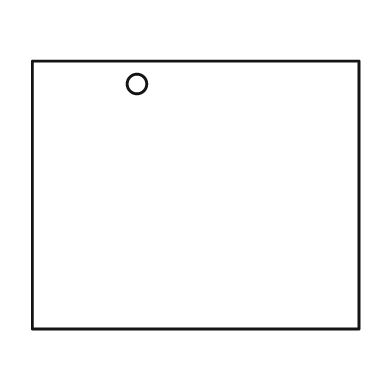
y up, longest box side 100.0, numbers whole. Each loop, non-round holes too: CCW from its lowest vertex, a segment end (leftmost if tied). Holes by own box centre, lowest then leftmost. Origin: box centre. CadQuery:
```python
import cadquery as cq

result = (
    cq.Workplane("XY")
    .moveTo(-50.0, -41.0)
    .lineTo(50.0, -41.0)
    .lineTo(50.0, 41.0)
    .lineTo(-50.0, 41.0)
    .close()
    .moveTo(-18.0, 34.0)
    .circle(3.0)
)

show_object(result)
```